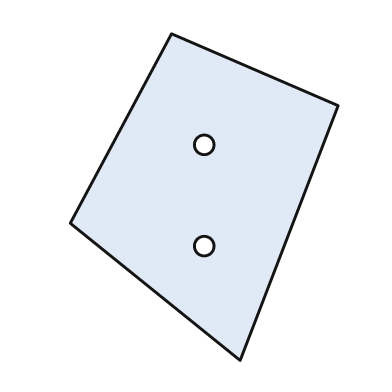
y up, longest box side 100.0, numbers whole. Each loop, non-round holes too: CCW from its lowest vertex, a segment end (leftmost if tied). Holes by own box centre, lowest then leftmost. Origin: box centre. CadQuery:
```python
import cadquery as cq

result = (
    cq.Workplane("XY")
    .moveTo(11.0, -50.0)
    .lineTo(41.0, 28.0)
    .lineTo(-10.0, 50.0)
    .lineTo(-41.0, -8.0)
    .close()
    .moveTo(0.0, -15.0)
    .circle(3.0)
    .moveTo(0.0, 16.0)
    .circle(3.0)
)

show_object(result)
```